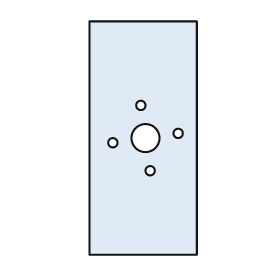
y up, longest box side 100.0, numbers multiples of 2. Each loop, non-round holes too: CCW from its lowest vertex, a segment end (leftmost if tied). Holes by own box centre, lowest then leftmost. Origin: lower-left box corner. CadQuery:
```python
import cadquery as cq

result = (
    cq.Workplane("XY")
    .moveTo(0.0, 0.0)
    .lineTo(46.0, 0.0)
    .lineTo(46.0, 100.0)
    .lineTo(0.0, 100.0)
    .close()
    .moveTo(26.0, 36.0)
    .circle(2.0)
    .moveTo(10.0, 48.0)
    .circle(2.0)
    .moveTo(24.0, 50.0)
    .circle(6.0)
    .moveTo(38.0, 52.0)
    .circle(2.0)
    .moveTo(22.0, 64.0)
    .circle(2.0)
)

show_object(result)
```